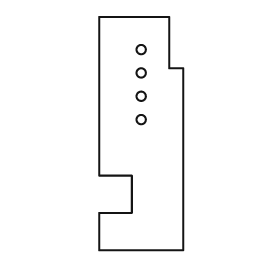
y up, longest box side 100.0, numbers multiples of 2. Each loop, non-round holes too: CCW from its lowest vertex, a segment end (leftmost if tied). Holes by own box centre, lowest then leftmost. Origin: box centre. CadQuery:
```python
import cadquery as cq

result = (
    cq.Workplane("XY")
    .moveTo(-18.0, -50.0)
    .lineTo(18.0, -50.0)
    .lineTo(18.0, 28.0)
    .lineTo(12.0, 28.0)
    .lineTo(12.0, 50.0)
    .lineTo(-18.0, 50.0)
    .lineTo(-18.0, -18.0)
    .lineTo(-4.0, -18.0)
    .lineTo(-4.0, -34.0)
    .lineTo(-18.0, -34.0)
    .close()
    .moveTo(0.0, 6.0)
    .circle(2.0)
    .moveTo(0.0, 16.0)
    .circle(2.0)
    .moveTo(0.0, 26.0)
    .circle(2.0)
    .moveTo(0.0, 36.0)
    .circle(2.0)
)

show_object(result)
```